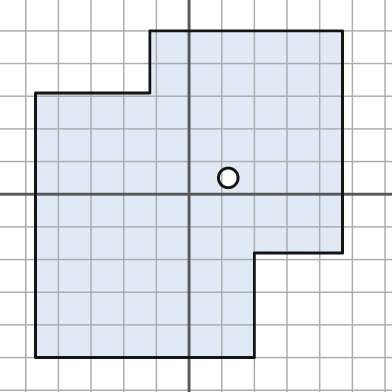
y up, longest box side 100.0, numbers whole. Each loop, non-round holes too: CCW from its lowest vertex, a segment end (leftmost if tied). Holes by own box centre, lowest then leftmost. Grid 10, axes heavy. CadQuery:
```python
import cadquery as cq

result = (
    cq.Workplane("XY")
    .moveTo(-47.0, -50.0)
    .lineTo(20.0, -50.0)
    .lineTo(20.0, -18.0)
    .lineTo(47.0, -18.0)
    .lineTo(47.0, 50.0)
    .lineTo(-12.0, 50.0)
    .lineTo(-12.0, 31.0)
    .lineTo(-47.0, 31.0)
    .close()
    .moveTo(12.0, 5.0)
    .circle(3.0)
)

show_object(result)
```